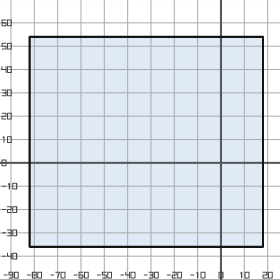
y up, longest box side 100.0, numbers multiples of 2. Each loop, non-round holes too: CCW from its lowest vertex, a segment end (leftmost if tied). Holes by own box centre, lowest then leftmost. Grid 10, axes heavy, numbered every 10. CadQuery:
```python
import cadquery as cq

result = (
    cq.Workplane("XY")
    .moveTo(-82.0, -36.0)
    .lineTo(18.0, -36.0)
    .lineTo(18.0, 54.0)
    .lineTo(-82.0, 54.0)
    .close()
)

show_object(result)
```